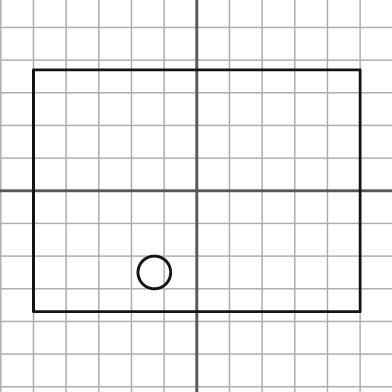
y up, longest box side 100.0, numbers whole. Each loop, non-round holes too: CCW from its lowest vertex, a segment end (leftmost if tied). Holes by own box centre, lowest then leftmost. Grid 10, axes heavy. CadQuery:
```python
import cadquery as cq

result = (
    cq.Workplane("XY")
    .moveTo(-50.0, -37.0)
    .lineTo(50.0, -37.0)
    .lineTo(50.0, 37.0)
    .lineTo(-50.0, 37.0)
    .close()
    .moveTo(-13.0, -25.0)
    .circle(5.0)
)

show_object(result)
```